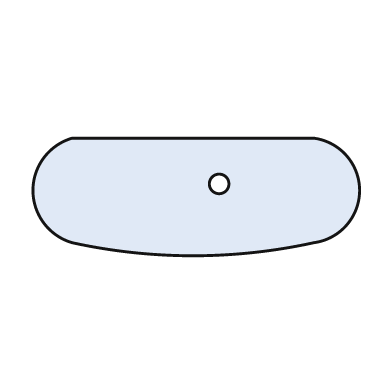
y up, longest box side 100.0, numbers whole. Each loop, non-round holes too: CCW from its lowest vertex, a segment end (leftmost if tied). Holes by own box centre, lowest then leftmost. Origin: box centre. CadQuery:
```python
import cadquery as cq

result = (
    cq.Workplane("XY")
    .moveTo(-38.0, -14.0)
    .threePointArc((-1.0, -18.0), (36.0, -14.0))
    .threePointArc((50.0, 2.0), (36.0, 18.0))
    .lineTo(-38.0, 18.0)
    .threePointArc((-50.0, 2.0), (-38.0, -14.0))
    .close()
    .moveTo(7.0, 4.0)
    .circle(3.0)
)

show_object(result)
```